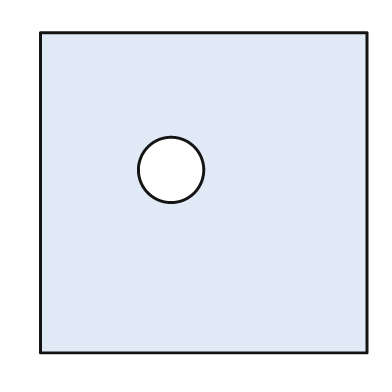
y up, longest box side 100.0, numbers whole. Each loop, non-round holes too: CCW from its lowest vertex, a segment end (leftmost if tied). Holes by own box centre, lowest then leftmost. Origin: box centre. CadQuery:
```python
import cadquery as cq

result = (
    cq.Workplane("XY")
    .moveTo(-50.0, -49.0)
    .lineTo(50.0, -49.0)
    .lineTo(50.0, 49.0)
    .lineTo(-50.0, 49.0)
    .close()
    .moveTo(-10.0, 7.0)
    .circle(10.0)
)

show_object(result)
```